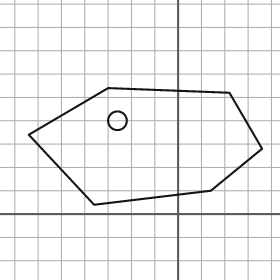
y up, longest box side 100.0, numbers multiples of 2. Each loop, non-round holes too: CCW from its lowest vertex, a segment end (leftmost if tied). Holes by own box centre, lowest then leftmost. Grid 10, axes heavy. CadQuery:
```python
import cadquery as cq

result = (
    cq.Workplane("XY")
    .moveTo(-36.0, 4.0)
    .lineTo(14.0, 10.0)
    .lineTo(36.0, 28.0)
    .lineTo(22.0, 52.0)
    .lineTo(-30.0, 54.0)
    .lineTo(-64.0, 34.0)
    .close()
    .moveTo(-26.0, 40.0)
    .circle(4.0)
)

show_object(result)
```